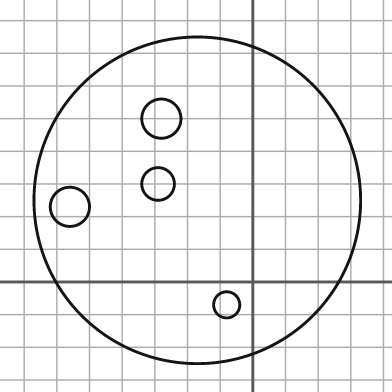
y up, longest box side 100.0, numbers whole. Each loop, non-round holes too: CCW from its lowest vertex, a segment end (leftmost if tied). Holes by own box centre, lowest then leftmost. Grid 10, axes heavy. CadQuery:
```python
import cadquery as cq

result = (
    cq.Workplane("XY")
    .moveTo(-17.0, 25.0)
    .circle(50.0)
    .moveTo(-8.0, -7.0)
    .circle(4.0)
    .moveTo(-56.0, 23.0)
    .circle(6.0)
    .moveTo(-29.0, 30.0)
    .circle(5.0)
    .moveTo(-28.0, 50.0)
    .circle(6.0)
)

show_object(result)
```